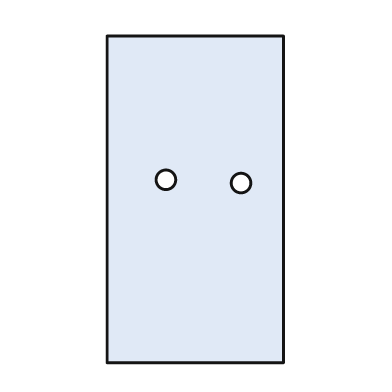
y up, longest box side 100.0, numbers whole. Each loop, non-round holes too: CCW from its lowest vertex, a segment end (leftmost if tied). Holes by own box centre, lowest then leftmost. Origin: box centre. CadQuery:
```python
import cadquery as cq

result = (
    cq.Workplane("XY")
    .moveTo(-27.0, -50.0)
    .lineTo(27.0, -50.0)
    .lineTo(27.0, 50.0)
    .lineTo(-27.0, 50.0)
    .close()
    .moveTo(14.0, 5.0)
    .circle(3.0)
    .moveTo(-9.0, 6.0)
    .circle(3.0)
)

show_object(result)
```